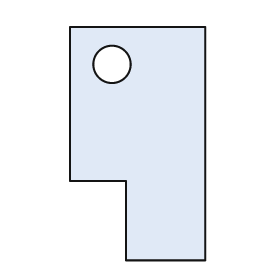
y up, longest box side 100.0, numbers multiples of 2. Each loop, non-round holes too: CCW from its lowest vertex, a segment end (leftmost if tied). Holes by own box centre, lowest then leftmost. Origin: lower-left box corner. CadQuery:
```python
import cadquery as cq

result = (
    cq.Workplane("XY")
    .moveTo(24.0, 0.0)
    .lineTo(58.0, 0.0)
    .lineTo(58.0, 100.0)
    .lineTo(0.0, 100.0)
    .lineTo(0.0, 34.0)
    .lineTo(24.0, 34.0)
    .close()
    .moveTo(18.0, 84.0)
    .circle(8.0)
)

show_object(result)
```